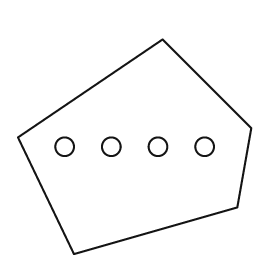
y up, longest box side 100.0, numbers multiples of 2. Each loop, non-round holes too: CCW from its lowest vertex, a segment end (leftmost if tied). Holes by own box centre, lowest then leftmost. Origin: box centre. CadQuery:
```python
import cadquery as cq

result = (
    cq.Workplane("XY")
    .moveTo(-26.0, -46.0)
    .lineTo(44.0, -26.0)
    .lineTo(50.0, 8.0)
    .lineTo(12.0, 46.0)
    .lineTo(-50.0, 4.0)
    .close()
    .moveTo(-30.0, 0.0)
    .circle(4.0)
    .moveTo(-10.0, 0.0)
    .circle(4.0)
    .moveTo(10.0, 0.0)
    .circle(4.0)
    .moveTo(30.0, 0.0)
    .circle(4.0)
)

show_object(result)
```